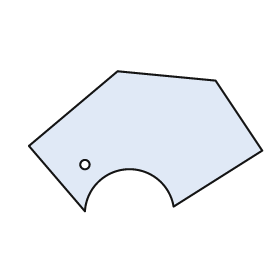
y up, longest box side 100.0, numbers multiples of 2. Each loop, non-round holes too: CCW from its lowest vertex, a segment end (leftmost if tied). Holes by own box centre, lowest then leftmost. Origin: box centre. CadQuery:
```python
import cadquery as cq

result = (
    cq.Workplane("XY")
    .moveTo(-26.0, -30.0)
    .threePointArc((-8.0, -12.0), (12.0, -28.0))
    .lineTo(50.0, -4.0)
    .lineTo(30.0, 26.0)
    .lineTo(-12.0, 30.0)
    .lineTo(-50.0, -2.0)
    .close()
    .moveTo(-26.0, -10.0)
    .circle(2.0)
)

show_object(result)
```